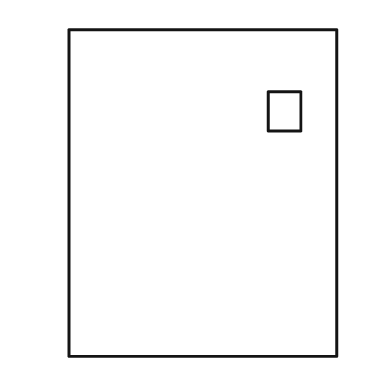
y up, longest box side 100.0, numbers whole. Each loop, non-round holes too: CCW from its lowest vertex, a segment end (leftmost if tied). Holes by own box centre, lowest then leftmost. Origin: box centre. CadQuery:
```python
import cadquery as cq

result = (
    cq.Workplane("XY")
    .moveTo(-41.0, -50.0)
    .lineTo(41.0, -50.0)
    .lineTo(41.0, 50.0)
    .lineTo(-41.0, 50.0)
    .close()
    .moveTo(20.0, 19.0)
    .lineTo(30.0, 19.0)
    .lineTo(30.0, 31.0)
    .lineTo(20.0, 31.0)
    .close()
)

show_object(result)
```